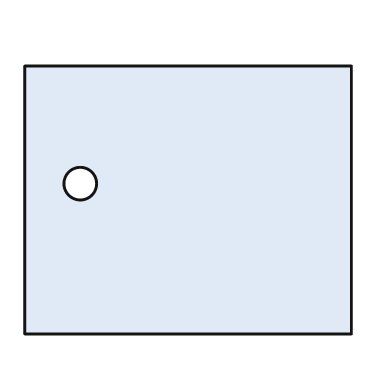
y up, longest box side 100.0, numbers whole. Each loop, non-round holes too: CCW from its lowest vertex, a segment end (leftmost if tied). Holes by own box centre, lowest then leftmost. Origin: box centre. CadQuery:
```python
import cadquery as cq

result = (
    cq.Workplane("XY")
    .moveTo(-50.0, -41.0)
    .lineTo(50.0, -41.0)
    .lineTo(50.0, 41.0)
    .lineTo(-50.0, 41.0)
    .close()
    .moveTo(-33.0, 5.0)
    .circle(5.0)
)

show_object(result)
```